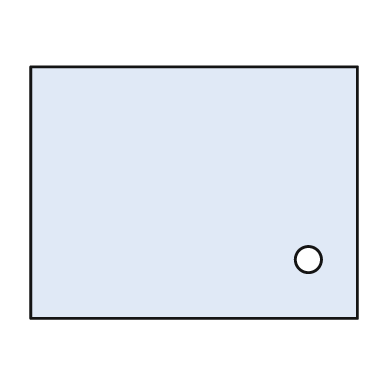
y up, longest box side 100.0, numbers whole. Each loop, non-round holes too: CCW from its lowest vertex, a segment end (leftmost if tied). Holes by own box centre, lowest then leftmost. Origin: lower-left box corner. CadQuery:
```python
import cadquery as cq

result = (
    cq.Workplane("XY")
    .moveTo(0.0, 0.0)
    .lineTo(100.0, 0.0)
    .lineTo(100.0, 77.0)
    .lineTo(0.0, 77.0)
    .close()
    .moveTo(85.0, 18.0)
    .circle(4.0)
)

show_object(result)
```